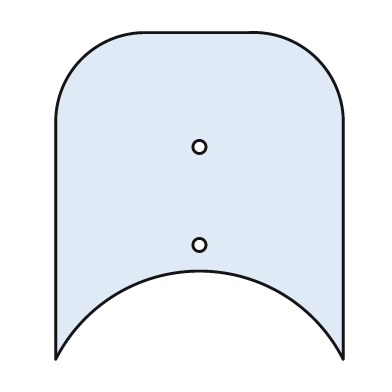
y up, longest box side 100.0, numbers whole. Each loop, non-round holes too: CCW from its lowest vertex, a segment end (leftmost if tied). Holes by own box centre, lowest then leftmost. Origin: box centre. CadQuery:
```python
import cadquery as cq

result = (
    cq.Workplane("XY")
    .moveTo(-44.0, -50.0)
    .threePointArc((0.0, -23.0), (44.0, -50.0))
    .lineTo(44.0, 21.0)
    .threePointArc((36.0, 42.0), (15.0, 50.0))
    .lineTo(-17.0, 50.0)
    .threePointArc((-36.0, 42.0), (-44.0, 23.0))
    .close()
    .moveTo(0.0, -15.0)
    .circle(2.0)
    .moveTo(0.0, 15.0)
    .circle(2.0)
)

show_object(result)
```